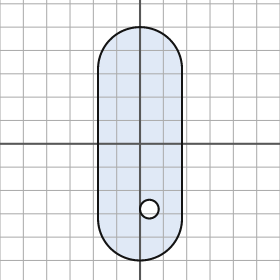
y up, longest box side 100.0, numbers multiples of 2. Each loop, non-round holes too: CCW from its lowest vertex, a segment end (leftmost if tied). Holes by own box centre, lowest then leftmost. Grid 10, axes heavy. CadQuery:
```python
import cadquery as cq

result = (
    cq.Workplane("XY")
    .moveTo(-18.0, -32.0)
    .threePointArc((0.0, -50.0), (18.0, -32.0))
    .lineTo(18.0, 32.0)
    .threePointArc((0.0, 50.0), (-18.0, 32.0))
    .close()
    .moveTo(4.0, -28.0)
    .circle(4.0)
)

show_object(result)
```